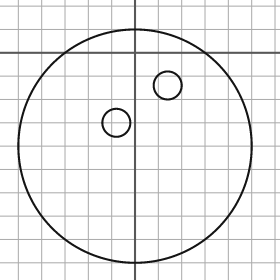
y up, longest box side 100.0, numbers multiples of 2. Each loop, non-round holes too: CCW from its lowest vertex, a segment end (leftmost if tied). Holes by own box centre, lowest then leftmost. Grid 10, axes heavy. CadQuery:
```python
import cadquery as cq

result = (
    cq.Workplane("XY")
    .moveTo(0.0, -40.0)
    .circle(50.0)
    .moveTo(-8.0, -30.0)
    .circle(6.0)
    .moveTo(14.0, -14.0)
    .circle(6.0)
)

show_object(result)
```